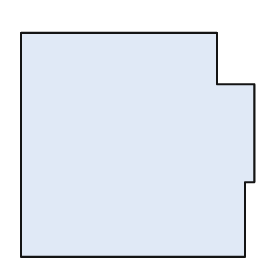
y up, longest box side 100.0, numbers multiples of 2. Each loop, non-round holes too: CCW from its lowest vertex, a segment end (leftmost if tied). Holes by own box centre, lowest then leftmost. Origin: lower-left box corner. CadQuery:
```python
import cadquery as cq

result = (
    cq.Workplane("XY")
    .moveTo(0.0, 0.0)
    .lineTo(96.0, 0.0)
    .lineTo(96.0, 32.0)
    .lineTo(100.0, 32.0)
    .lineTo(100.0, 74.0)
    .lineTo(84.0, 74.0)
    .lineTo(84.0, 96.0)
    .lineTo(0.0, 96.0)
    .close()
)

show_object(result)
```